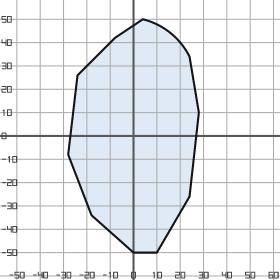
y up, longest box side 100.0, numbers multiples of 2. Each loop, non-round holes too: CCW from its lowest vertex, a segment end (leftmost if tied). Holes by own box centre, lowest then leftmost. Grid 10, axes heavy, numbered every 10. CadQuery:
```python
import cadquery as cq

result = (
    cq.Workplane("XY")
    .moveTo(0.0, -50.0)
    .lineTo(10.0, -50.0)
    .lineTo(24.0, -26.0)
    .lineTo(28.0, 10.0)
    .lineTo(24.0, 34.0)
    .threePointArc((16.0, 44.0), (4.0, 50.0))
    .lineTo(-8.0, 42.0)
    .lineTo(-24.0, 26.0)
    .lineTo(-28.0, -8.0)
    .lineTo(-18.0, -34.0)
    .close()
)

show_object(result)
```